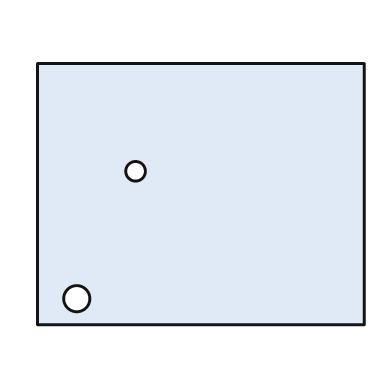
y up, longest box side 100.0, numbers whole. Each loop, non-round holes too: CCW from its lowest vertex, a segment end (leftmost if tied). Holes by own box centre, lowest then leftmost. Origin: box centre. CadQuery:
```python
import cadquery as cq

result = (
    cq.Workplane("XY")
    .moveTo(-50.0, -40.0)
    .lineTo(50.0, -40.0)
    .lineTo(50.0, 40.0)
    .lineTo(-50.0, 40.0)
    .close()
    .moveTo(-38.0, -32.0)
    .circle(4.0)
    .moveTo(-20.0, 7.0)
    .circle(3.0)
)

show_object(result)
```